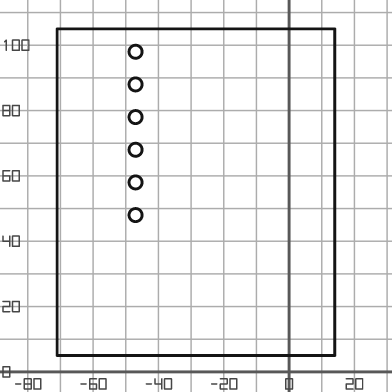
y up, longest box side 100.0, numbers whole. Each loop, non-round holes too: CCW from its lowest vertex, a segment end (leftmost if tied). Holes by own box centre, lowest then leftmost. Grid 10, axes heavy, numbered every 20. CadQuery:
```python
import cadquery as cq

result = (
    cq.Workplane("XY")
    .moveTo(-71.0, 5.0)
    .lineTo(14.0, 5.0)
    .lineTo(14.0, 105.0)
    .lineTo(-71.0, 105.0)
    .close()
    .moveTo(-47.0, 48.0)
    .circle(2.0)
    .moveTo(-47.0, 58.0)
    .circle(2.0)
    .moveTo(-47.0, 68.0)
    .circle(2.0)
    .moveTo(-47.0, 78.0)
    .circle(2.0)
    .moveTo(-47.0, 88.0)
    .circle(2.0)
    .moveTo(-47.0, 98.0)
    .circle(2.0)
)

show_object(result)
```